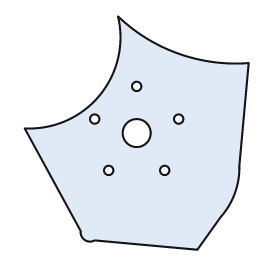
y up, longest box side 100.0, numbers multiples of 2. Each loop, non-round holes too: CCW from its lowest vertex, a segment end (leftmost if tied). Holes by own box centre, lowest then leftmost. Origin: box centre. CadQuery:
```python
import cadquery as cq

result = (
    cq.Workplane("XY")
    .moveTo(26.0, -50.0)
    .lineTo(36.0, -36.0)
    .threePointArc((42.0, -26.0), (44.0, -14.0))
    .lineTo(48.0, 30.0)
    .threePointArc((18.0, 34.0), (-8.0, 50.0))
    .threePointArc((-16.0, 16.0), (-48.0, 2.0))
    .lineTo(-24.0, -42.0)
    .threePointArc((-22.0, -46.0), (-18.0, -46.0))
    .close()
    .moveTo(-12.0, -16.0)
    .circle(2.0)
    .moveTo(12.0, -16.0)
    .circle(2.0)
    .moveTo(0.0, 0.0)
    .circle(6.0)
    .moveTo(-18.0, 6.0)
    .circle(2.0)
    .moveTo(18.0, 6.0)
    .circle(2.0)
    .moveTo(0.0, 20.0)
    .circle(2.0)
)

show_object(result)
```